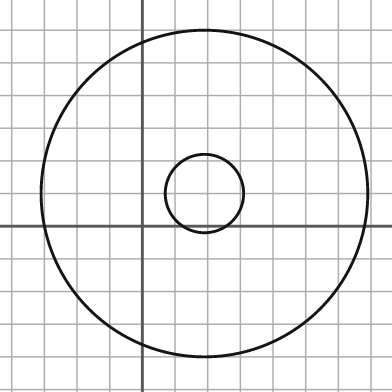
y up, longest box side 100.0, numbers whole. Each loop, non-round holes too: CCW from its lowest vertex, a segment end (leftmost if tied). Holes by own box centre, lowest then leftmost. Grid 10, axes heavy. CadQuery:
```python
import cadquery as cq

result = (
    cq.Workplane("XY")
    .moveTo(19.0, 10.0)
    .circle(50.0)
    .moveTo(19.0, 10.0)
    .circle(12.0)
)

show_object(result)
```